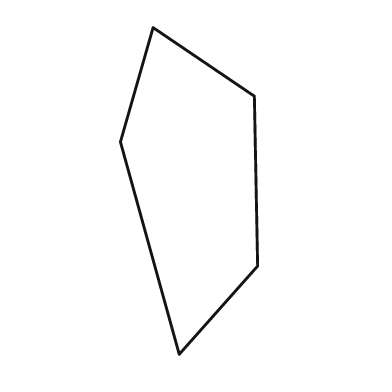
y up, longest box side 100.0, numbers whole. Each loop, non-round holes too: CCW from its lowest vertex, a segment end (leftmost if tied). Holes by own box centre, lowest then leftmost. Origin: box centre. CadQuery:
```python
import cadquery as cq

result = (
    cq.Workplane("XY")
    .moveTo(-3.0, -50.0)
    .lineTo(21.0, -23.0)
    .lineTo(20.0, 29.0)
    .lineTo(-11.0, 50.0)
    .lineTo(-21.0, 15.0)
    .close()
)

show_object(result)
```